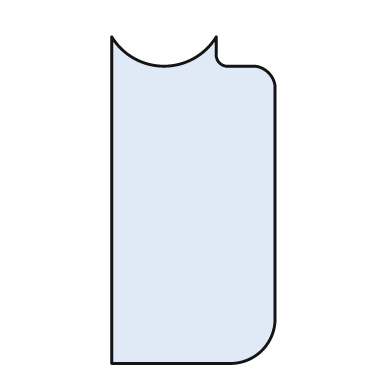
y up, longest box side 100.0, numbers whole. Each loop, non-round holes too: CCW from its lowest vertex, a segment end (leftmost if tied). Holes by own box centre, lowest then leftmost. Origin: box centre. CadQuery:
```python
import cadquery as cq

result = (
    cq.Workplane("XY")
    .moveTo(-25.0, -50.0)
    .lineTo(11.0, -50.0)
    .threePointArc((21.0, -46.0), (25.0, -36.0))
    .lineTo(25.0, 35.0)
    .threePointArc((23.0, 39.0), (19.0, 41.0))
    .lineTo(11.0, 41.0)
    .threePointArc((8.0, 42.0), (7.0, 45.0))
    .lineTo(7.0, 50.0)
    .threePointArc((-9.0, 41.0), (-25.0, 50.0))
    .close()
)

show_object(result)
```